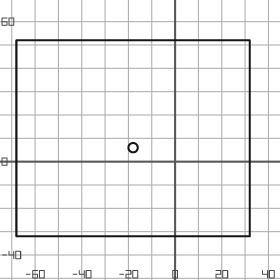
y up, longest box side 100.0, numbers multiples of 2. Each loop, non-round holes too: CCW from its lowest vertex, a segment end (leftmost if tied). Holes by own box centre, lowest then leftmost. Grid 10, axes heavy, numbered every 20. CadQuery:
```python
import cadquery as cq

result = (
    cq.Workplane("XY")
    .moveTo(-68.0, -32.0)
    .lineTo(32.0, -32.0)
    .lineTo(32.0, 52.0)
    .lineTo(-68.0, 52.0)
    .close()
    .moveTo(-18.0, 6.0)
    .circle(2.0)
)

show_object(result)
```